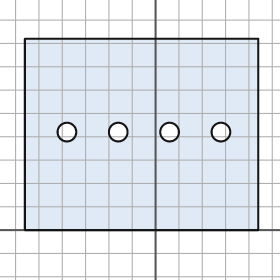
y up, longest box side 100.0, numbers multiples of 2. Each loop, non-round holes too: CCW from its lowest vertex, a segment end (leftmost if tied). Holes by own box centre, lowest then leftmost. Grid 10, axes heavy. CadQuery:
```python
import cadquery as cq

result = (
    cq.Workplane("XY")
    .moveTo(-56.0, 0.0)
    .lineTo(44.0, 0.0)
    .lineTo(44.0, 82.0)
    .lineTo(-56.0, 82.0)
    .close()
    .moveTo(-38.0, 42.0)
    .circle(4.0)
    .moveTo(-16.0, 42.0)
    .circle(4.0)
    .moveTo(6.0, 42.0)
    .circle(4.0)
    .moveTo(28.0, 42.0)
    .circle(4.0)
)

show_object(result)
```